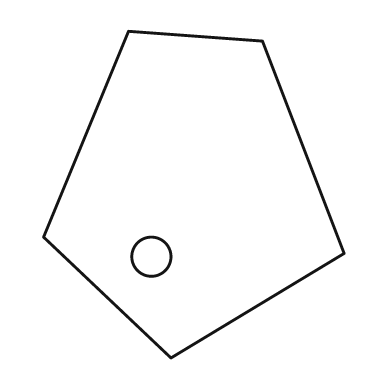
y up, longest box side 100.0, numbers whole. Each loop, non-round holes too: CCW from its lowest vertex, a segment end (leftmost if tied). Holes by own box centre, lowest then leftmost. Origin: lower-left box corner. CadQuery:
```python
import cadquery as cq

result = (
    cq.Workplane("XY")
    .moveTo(39.0, 0.0)
    .lineTo(92.0, 32.0)
    .lineTo(67.0, 97.0)
    .lineTo(26.0, 100.0)
    .lineTo(0.0, 37.0)
    .close()
    .moveTo(33.0, 31.0)
    .circle(6.0)
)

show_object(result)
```